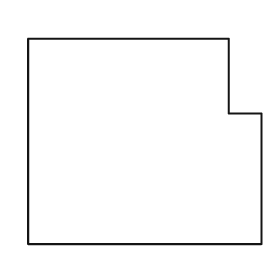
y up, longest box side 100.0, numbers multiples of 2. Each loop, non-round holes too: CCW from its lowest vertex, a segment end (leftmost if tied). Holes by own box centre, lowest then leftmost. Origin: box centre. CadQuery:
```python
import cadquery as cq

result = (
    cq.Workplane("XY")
    .moveTo(-50.0, -44.0)
    .lineTo(50.0, -44.0)
    .lineTo(50.0, 12.0)
    .lineTo(36.0, 12.0)
    .lineTo(36.0, 44.0)
    .lineTo(-50.0, 44.0)
    .close()
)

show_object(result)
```